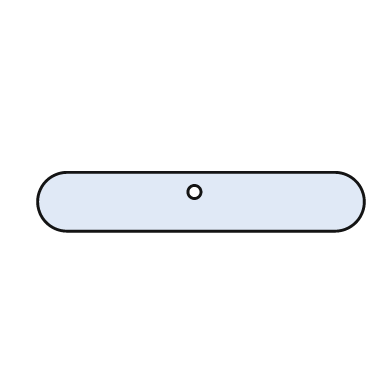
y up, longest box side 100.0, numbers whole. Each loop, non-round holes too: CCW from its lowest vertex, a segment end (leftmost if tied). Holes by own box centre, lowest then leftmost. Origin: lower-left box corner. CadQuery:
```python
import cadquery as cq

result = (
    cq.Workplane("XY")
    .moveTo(9.0, 0.0)
    .lineTo(91.0, 0.0)
    .threePointArc((100.0, 9.0), (91.0, 18.0))
    .lineTo(9.0, 18.0)
    .threePointArc((0.0, 9.0), (9.0, 0.0))
    .close()
    .moveTo(48.0, 12.0)
    .circle(2.0)
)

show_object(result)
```